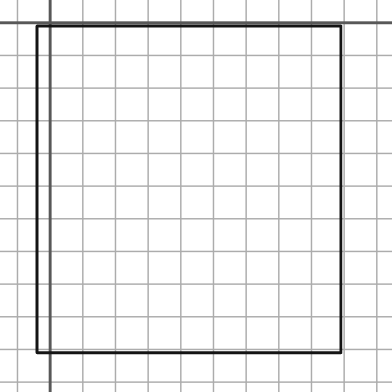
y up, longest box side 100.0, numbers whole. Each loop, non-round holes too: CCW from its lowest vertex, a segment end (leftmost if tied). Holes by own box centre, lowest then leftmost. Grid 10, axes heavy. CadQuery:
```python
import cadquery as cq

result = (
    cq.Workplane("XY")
    .moveTo(-4.0, -101.0)
    .lineTo(89.0, -101.0)
    .lineTo(89.0, -1.0)
    .lineTo(-4.0, -1.0)
    .close()
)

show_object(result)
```